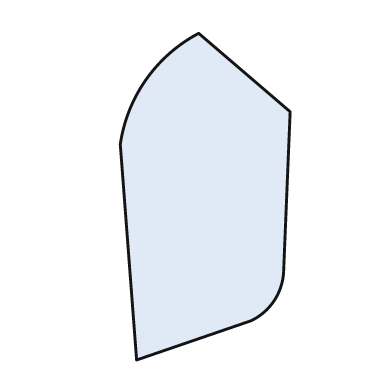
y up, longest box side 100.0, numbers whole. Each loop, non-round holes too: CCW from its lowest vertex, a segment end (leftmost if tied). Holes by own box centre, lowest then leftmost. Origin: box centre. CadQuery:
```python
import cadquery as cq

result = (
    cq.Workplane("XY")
    .moveTo(-21.0, -50.0)
    .lineTo(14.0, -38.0)
    .threePointArc((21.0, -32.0), (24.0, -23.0))
    .lineTo(26.0, 26.0)
    .lineTo(-2.0, 50.0)
    .threePointArc((-18.0, 36.0), (-26.0, 16.0))
    .close()
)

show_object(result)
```